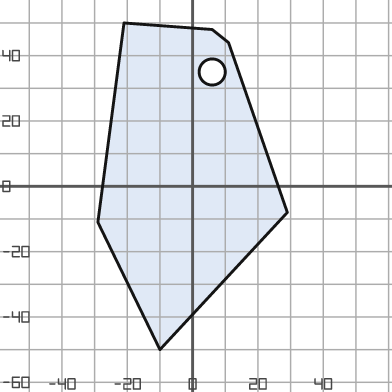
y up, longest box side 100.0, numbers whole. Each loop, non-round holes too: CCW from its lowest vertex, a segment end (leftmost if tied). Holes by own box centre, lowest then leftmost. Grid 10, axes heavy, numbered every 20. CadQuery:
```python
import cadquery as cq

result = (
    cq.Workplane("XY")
    .moveTo(-10.0, -50.0)
    .lineTo(29.0, -8.0)
    .lineTo(11.0, 44.0)
    .lineTo(6.0, 48.0)
    .lineTo(-21.0, 50.0)
    .lineTo(-29.0, -11.0)
    .close()
    .moveTo(6.0, 35.0)
    .circle(4.0)
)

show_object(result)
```